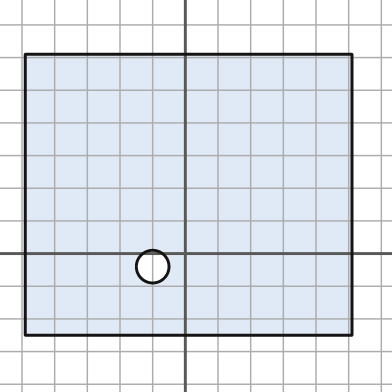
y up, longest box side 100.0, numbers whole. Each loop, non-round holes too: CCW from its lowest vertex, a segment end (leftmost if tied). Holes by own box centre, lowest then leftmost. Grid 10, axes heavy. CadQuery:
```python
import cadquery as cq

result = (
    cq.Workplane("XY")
    .moveTo(-49.0, -25.0)
    .lineTo(51.0, -25.0)
    .lineTo(51.0, 61.0)
    .lineTo(-49.0, 61.0)
    .close()
    .moveTo(-10.0, -4.0)
    .circle(5.0)
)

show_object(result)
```